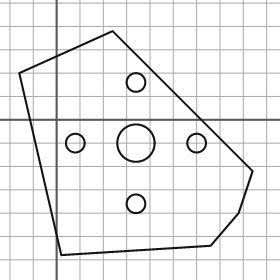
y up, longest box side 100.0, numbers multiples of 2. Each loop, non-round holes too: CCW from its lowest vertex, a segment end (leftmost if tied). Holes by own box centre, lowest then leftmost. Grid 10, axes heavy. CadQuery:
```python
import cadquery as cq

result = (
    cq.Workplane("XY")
    .moveTo(2.0, -58.0)
    .lineTo(66.0, -54.0)
    .lineTo(78.0, -40.0)
    .lineTo(84.0, -22.0)
    .lineTo(24.0, 38.0)
    .lineTo(-16.0, 20.0)
    .close()
    .moveTo(34.0, -36.0)
    .circle(4.0)
    .moveTo(8.0, -10.0)
    .circle(4.0)
    .moveTo(34.0, -10.0)
    .circle(8.0)
    .moveTo(60.0, -10.0)
    .circle(4.0)
    .moveTo(34.0, 16.0)
    .circle(4.0)
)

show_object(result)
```